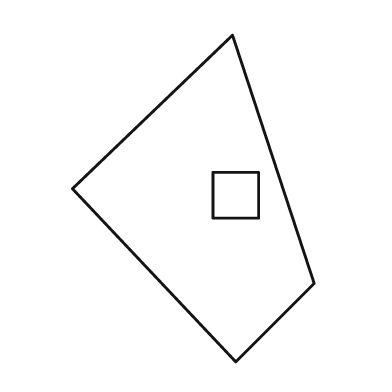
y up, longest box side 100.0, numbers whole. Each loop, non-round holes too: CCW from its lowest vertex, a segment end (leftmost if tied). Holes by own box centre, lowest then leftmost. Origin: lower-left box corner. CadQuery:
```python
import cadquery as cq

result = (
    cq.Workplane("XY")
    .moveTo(50.0, 0.0)
    .lineTo(74.0, 24.0)
    .lineTo(49.0, 100.0)
    .lineTo(0.0, 53.0)
    .close()
    .moveTo(43.0, 44.0)
    .lineTo(57.0, 44.0)
    .lineTo(57.0, 58.0)
    .lineTo(43.0, 58.0)
    .close()
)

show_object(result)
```